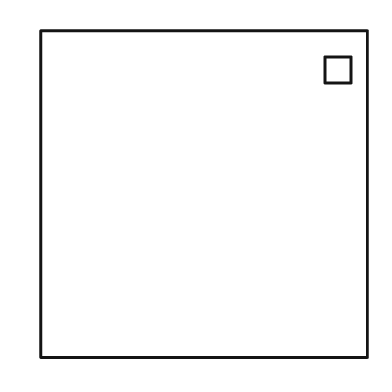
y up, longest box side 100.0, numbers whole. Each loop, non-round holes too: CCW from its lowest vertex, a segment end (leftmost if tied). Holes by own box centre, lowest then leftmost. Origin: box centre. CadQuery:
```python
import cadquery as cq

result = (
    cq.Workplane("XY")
    .moveTo(-50.0, -50.0)
    .lineTo(50.0, -50.0)
    .lineTo(50.0, 50.0)
    .lineTo(-50.0, 50.0)
    .close()
    .moveTo(37.0, 34.0)
    .lineTo(45.0, 34.0)
    .lineTo(45.0, 42.0)
    .lineTo(37.0, 42.0)
    .close()
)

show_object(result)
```